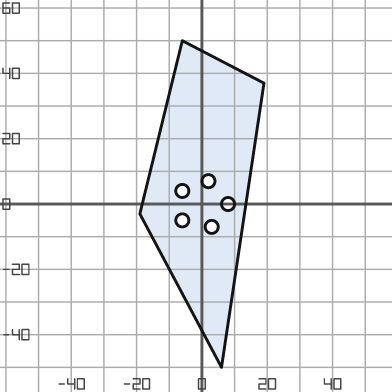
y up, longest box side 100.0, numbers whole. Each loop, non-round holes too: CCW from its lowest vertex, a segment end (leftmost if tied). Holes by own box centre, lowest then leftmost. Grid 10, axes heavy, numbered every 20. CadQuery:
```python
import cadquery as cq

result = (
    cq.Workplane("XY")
    .moveTo(6.0, -50.0)
    .lineTo(19.0, 37.0)
    .lineTo(-6.0, 50.0)
    .lineTo(-19.0, -3.0)
    .close()
    .moveTo(3.0, -7.0)
    .circle(2.0)
    .moveTo(-6.0, -5.0)
    .circle(2.0)
    .moveTo(8.0, 0.0)
    .circle(2.0)
    .moveTo(-6.0, 4.0)
    .circle(2.0)
    .moveTo(2.0, 7.0)
    .circle(2.0)
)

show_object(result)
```